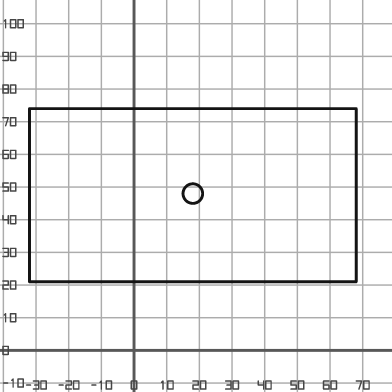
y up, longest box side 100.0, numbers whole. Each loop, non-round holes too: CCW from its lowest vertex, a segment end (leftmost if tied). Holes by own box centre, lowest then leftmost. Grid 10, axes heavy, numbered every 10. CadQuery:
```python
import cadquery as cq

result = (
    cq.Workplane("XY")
    .moveTo(-32.0, 21.0)
    .lineTo(68.0, 21.0)
    .lineTo(68.0, 74.0)
    .lineTo(-32.0, 74.0)
    .close()
    .moveTo(18.0, 48.0)
    .circle(3.0)
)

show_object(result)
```